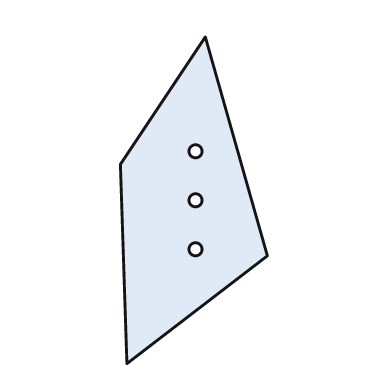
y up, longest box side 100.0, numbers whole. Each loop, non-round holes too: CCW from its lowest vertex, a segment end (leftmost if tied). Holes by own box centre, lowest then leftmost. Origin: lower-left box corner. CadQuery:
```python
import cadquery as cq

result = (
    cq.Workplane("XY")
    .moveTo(2.0, 0.0)
    .lineTo(45.0, 33.0)
    .lineTo(26.0, 100.0)
    .lineTo(0.0, 61.0)
    .close()
    .moveTo(23.0, 35.0)
    .circle(2.0)
    .moveTo(23.0, 50.0)
    .circle(2.0)
    .moveTo(23.0, 65.0)
    .circle(2.0)
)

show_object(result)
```